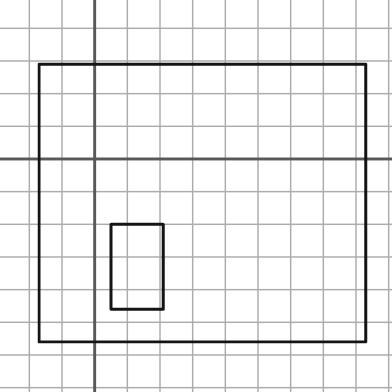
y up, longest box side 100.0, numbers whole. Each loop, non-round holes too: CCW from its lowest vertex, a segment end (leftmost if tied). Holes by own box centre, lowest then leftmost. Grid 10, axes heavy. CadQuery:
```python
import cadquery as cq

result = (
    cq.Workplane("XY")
    .moveTo(-17.0, -56.0)
    .lineTo(83.0, -56.0)
    .lineTo(83.0, 29.0)
    .lineTo(-17.0, 29.0)
    .close()
    .moveTo(5.0, -46.0)
    .lineTo(21.0, -46.0)
    .lineTo(21.0, -20.0)
    .lineTo(5.0, -20.0)
    .close()
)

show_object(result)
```